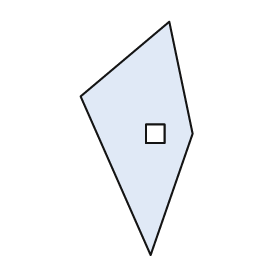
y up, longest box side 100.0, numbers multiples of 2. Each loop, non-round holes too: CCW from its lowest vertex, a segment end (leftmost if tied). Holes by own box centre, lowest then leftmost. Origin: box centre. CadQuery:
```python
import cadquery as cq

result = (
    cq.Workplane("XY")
    .moveTo(6.0, -50.0)
    .lineTo(24.0, 2.0)
    .lineTo(14.0, 50.0)
    .lineTo(-24.0, 18.0)
    .close()
    .moveTo(4.0, -2.0)
    .lineTo(12.0, -2.0)
    .lineTo(12.0, 6.0)
    .lineTo(4.0, 6.0)
    .close()
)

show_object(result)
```